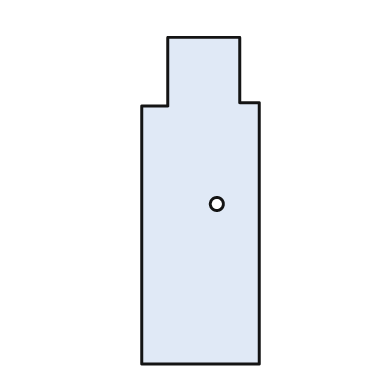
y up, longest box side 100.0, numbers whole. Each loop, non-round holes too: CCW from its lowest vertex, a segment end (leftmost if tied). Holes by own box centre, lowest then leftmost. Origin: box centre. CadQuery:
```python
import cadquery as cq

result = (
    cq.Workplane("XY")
    .moveTo(-18.0, -50.0)
    .lineTo(18.0, -50.0)
    .lineTo(18.0, 30.0)
    .lineTo(12.0, 30.0)
    .lineTo(12.0, 50.0)
    .lineTo(-10.0, 50.0)
    .lineTo(-10.0, 29.0)
    .lineTo(-18.0, 29.0)
    .close()
    .moveTo(5.0, -1.0)
    .circle(2.0)
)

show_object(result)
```